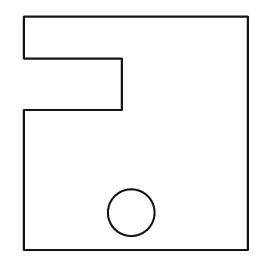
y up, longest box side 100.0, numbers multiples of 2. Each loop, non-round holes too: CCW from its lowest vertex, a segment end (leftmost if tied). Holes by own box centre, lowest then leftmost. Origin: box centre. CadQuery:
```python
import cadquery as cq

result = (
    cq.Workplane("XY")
    .moveTo(-48.0, -50.0)
    .lineTo(48.0, -50.0)
    .lineTo(48.0, 50.0)
    .lineTo(-48.0, 50.0)
    .lineTo(-48.0, 32.0)
    .lineTo(-6.0, 32.0)
    .lineTo(-6.0, 10.0)
    .lineTo(-48.0, 10.0)
    .close()
    .moveTo(-2.0, -34.0)
    .circle(10.0)
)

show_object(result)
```